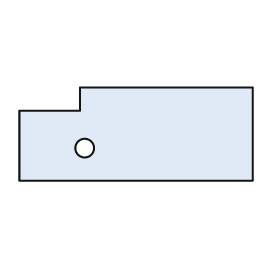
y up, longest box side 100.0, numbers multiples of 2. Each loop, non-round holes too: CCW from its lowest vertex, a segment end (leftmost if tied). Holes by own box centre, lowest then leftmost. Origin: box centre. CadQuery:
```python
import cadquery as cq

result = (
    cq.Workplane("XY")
    .moveTo(-50.0, -20.0)
    .lineTo(50.0, -20.0)
    .lineTo(50.0, 20.0)
    .lineTo(-24.0, 20.0)
    .lineTo(-24.0, 10.0)
    .lineTo(-50.0, 10.0)
    .close()
    .moveTo(-22.0, -6.0)
    .circle(4.0)
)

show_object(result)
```